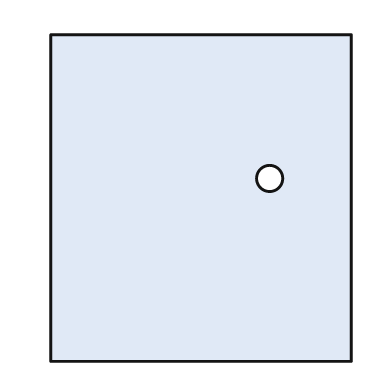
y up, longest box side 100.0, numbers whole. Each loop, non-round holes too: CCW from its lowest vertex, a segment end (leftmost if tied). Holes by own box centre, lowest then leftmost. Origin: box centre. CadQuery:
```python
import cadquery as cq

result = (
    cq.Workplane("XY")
    .moveTo(-46.0, -50.0)
    .lineTo(46.0, -50.0)
    .lineTo(46.0, 50.0)
    .lineTo(-46.0, 50.0)
    .close()
    .moveTo(21.0, 6.0)
    .circle(4.0)
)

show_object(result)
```